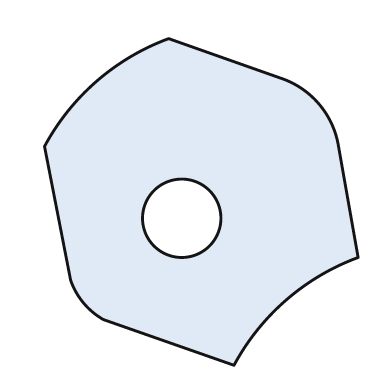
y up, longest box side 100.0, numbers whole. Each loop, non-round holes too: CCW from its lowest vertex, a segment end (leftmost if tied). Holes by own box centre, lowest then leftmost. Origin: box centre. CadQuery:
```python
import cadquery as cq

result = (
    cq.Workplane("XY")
    .moveTo(10.0, -50.0)
    .threePointArc((26.0, -30.0), (48.0, -17.0))
    .lineTo(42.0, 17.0)
    .threePointArc((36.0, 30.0), (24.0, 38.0))
    .lineTo(-10.0, 50.0)
    .threePointArc((-32.0, 37.0), (-48.0, 17.0))
    .lineTo(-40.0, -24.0)
    .threePointArc((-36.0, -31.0), (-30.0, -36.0))
    .close()
    .moveTo(-6.0, -5.0)
    .circle(12.0)
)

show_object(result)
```